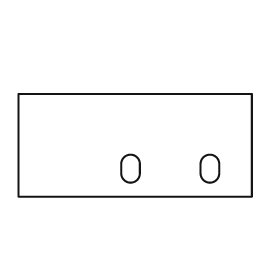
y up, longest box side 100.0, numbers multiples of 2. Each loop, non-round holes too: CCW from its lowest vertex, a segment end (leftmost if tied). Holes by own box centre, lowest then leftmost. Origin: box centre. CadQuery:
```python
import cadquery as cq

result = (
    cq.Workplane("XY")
    .moveTo(-50.0, -22.0)
    .lineTo(50.0, -22.0)
    .lineTo(50.0, 22.0)
    .lineTo(-50.0, 22.0)
    .close()
    .moveTo(-6.0, -12.0)
    .threePointArc((-2.0, -16.0), (2.0, -12.0))
    .lineTo(2.0, -8.0)
    .threePointArc((-2.0, -4.0), (-6.0, -8.0))
    .close()
    .moveTo(28.0, -12.0)
    .threePointArc((32.0, -16.0), (36.0, -12.0))
    .lineTo(36.0, -8.0)
    .threePointArc((32.0, -4.0), (28.0, -8.0))
    .close()
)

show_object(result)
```